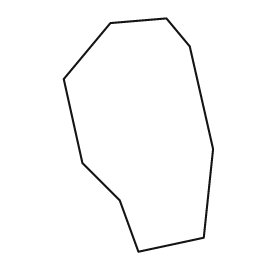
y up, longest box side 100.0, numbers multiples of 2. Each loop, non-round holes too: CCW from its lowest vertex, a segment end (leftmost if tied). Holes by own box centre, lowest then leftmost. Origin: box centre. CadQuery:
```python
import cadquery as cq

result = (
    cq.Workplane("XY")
    .moveTo(0.0, -50.0)
    .lineTo(28.0, -44.0)
    .lineTo(32.0, -6.0)
    .lineTo(22.0, 38.0)
    .lineTo(12.0, 50.0)
    .lineTo(-12.0, 48.0)
    .lineTo(-32.0, 24.0)
    .lineTo(-24.0, -12.0)
    .lineTo(-8.0, -28.0)
    .close()
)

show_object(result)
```